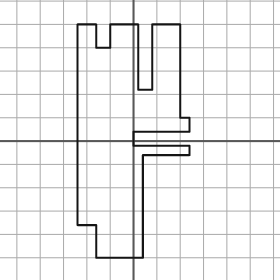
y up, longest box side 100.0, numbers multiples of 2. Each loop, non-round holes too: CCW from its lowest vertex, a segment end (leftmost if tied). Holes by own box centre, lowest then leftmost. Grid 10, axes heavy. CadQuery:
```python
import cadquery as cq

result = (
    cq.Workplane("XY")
    .moveTo(-16.0, -50.0)
    .lineTo(4.0, -50.0)
    .lineTo(4.0, -6.0)
    .lineTo(24.0, -6.0)
    .lineTo(24.0, -2.0)
    .lineTo(0.0, -2.0)
    .lineTo(0.0, 4.0)
    .lineTo(24.0, 4.0)
    .lineTo(24.0, 10.0)
    .lineTo(20.0, 10.0)
    .lineTo(20.0, 50.0)
    .lineTo(8.0, 50.0)
    .lineTo(8.0, 22.0)
    .lineTo(2.0, 22.0)
    .lineTo(2.0, 50.0)
    .lineTo(-10.0, 50.0)
    .lineTo(-10.0, 40.0)
    .lineTo(-16.0, 40.0)
    .lineTo(-16.0, 50.0)
    .lineTo(-24.0, 50.0)
    .lineTo(-24.0, -36.0)
    .lineTo(-16.0, -36.0)
    .close()
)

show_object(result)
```